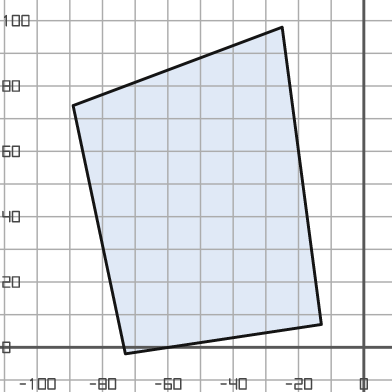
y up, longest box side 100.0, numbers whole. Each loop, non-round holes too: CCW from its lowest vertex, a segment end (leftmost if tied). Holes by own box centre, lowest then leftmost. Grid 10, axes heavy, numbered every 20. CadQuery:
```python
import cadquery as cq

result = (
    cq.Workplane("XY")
    .moveTo(-73.0, -2.0)
    .lineTo(-13.0, 7.0)
    .lineTo(-25.0, 98.0)
    .lineTo(-89.0, 74.0)
    .close()
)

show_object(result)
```